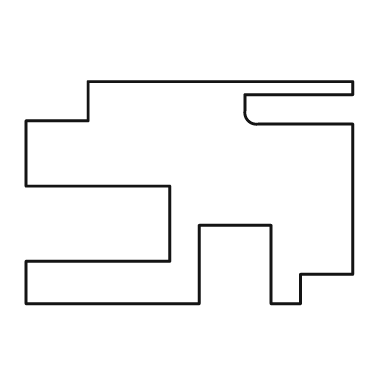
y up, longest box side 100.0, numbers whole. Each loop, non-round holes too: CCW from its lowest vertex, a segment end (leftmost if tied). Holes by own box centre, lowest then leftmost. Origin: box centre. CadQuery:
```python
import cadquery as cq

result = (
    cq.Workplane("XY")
    .moveTo(-50.0, -34.0)
    .lineTo(3.0, -34.0)
    .lineTo(3.0, -10.0)
    .lineTo(25.0, -10.0)
    .lineTo(25.0, -34.0)
    .lineTo(34.0, -34.0)
    .lineTo(34.0, -25.0)
    .lineTo(50.0, -25.0)
    .lineTo(50.0, 21.0)
    .lineTo(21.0, 21.0)
    .threePointArc((18.0, 22.0), (17.0, 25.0))
    .lineTo(17.0, 30.0)
    .lineTo(50.0, 30.0)
    .lineTo(50.0, 34.0)
    .lineTo(-31.0, 34.0)
    .lineTo(-31.0, 22.0)
    .lineTo(-50.0, 22.0)
    .lineTo(-50.0, 2.0)
    .lineTo(-6.0, 2.0)
    .lineTo(-6.0, -21.0)
    .lineTo(-50.0, -21.0)
    .close()
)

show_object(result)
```